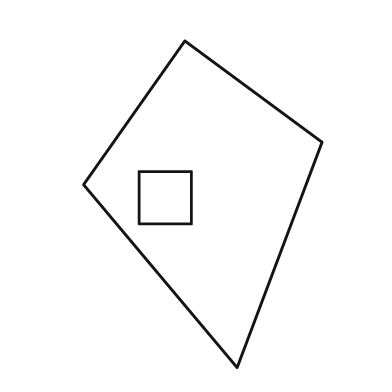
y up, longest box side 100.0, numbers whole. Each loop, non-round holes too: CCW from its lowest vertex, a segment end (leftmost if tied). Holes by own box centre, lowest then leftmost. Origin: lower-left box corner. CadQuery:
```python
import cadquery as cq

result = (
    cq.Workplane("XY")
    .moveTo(47.0, 0.0)
    .lineTo(73.0, 69.0)
    .lineTo(31.0, 100.0)
    .lineTo(0.0, 56.0)
    .close()
    .moveTo(17.0, 44.0)
    .lineTo(33.0, 44.0)
    .lineTo(33.0, 60.0)
    .lineTo(17.0, 60.0)
    .close()
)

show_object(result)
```